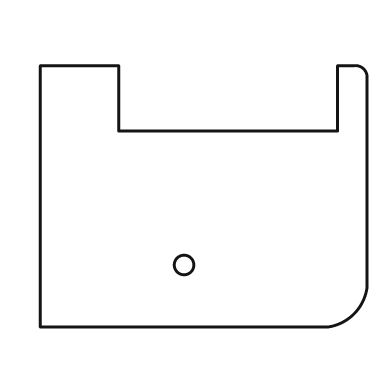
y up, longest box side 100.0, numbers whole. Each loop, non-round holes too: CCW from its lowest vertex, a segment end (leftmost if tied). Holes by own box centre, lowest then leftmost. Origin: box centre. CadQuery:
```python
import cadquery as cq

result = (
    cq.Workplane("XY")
    .moveTo(-50.0, -40.0)
    .lineTo(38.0, -40.0)
    .threePointArc((46.0, -36.0), (50.0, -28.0))
    .lineTo(50.0, 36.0)
    .threePointArc((49.0, 39.0), (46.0, 40.0))
    .lineTo(41.0, 40.0)
    .lineTo(41.0, 20.0)
    .lineTo(-26.0, 20.0)
    .lineTo(-26.0, 40.0)
    .lineTo(-50.0, 40.0)
    .close()
    .moveTo(-6.0, -21.0)
    .circle(3.0)
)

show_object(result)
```